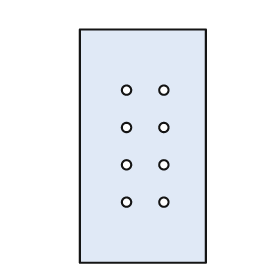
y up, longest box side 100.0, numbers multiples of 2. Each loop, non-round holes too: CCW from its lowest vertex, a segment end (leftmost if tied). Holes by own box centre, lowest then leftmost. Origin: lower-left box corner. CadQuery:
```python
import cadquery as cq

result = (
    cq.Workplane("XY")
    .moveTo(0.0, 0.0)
    .lineTo(54.0, 0.0)
    .lineTo(54.0, 100.0)
    .lineTo(0.0, 100.0)
    .close()
    .moveTo(20.0, 26.0)
    .circle(2.0)
    .moveTo(36.0, 26.0)
    .circle(2.0)
    .moveTo(20.0, 42.0)
    .circle(2.0)
    .moveTo(36.0, 42.0)
    .circle(2.0)
    .moveTo(20.0, 58.0)
    .circle(2.0)
    .moveTo(36.0, 58.0)
    .circle(2.0)
    .moveTo(20.0, 74.0)
    .circle(2.0)
    .moveTo(36.0, 74.0)
    .circle(2.0)
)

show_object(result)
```